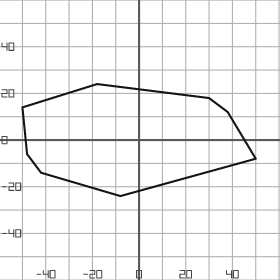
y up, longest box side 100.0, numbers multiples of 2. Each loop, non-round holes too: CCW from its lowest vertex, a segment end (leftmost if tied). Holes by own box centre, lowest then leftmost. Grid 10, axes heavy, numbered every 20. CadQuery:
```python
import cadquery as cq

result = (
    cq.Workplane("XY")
    .moveTo(-8.0, -24.0)
    .lineTo(50.0, -8.0)
    .lineTo(38.0, 12.0)
    .lineTo(30.0, 18.0)
    .lineTo(-18.0, 24.0)
    .lineTo(-50.0, 14.0)
    .lineTo(-48.0, -6.0)
    .lineTo(-42.0, -14.0)
    .close()
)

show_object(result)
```